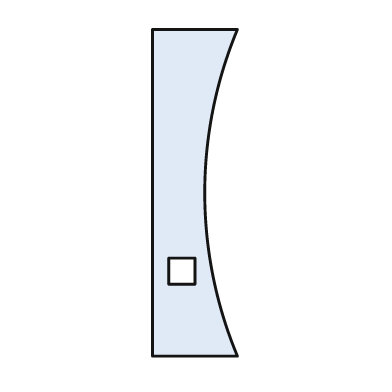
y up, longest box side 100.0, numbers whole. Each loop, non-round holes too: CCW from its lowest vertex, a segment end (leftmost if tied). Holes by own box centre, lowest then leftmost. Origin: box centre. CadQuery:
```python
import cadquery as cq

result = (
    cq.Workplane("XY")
    .moveTo(-13.0, -50.0)
    .lineTo(13.0, -50.0)
    .threePointArc((3.0, 0.0), (13.0, 50.0))
    .lineTo(-13.0, 50.0)
    .close()
    .moveTo(-8.0, -28.0)
    .lineTo(0.0, -28.0)
    .lineTo(0.0, -20.0)
    .lineTo(-8.0, -20.0)
    .close()
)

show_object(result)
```